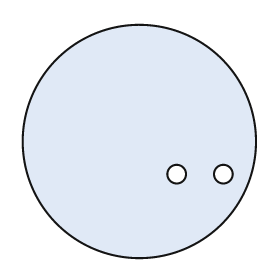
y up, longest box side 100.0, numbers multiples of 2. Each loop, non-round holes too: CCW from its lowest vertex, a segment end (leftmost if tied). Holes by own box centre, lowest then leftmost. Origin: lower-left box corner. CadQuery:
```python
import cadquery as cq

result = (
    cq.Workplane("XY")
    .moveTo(50.0, 50.0)
    .circle(50.0)
    .moveTo(66.0, 36.0)
    .circle(4.0)
    .moveTo(86.0, 36.0)
    .circle(4.0)
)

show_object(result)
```